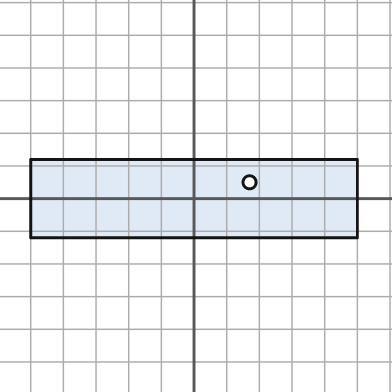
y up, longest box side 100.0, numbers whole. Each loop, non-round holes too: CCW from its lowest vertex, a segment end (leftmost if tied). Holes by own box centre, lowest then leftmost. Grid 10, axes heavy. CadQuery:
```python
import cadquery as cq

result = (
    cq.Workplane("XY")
    .moveTo(-50.0, -12.0)
    .lineTo(50.0, -12.0)
    .lineTo(50.0, 12.0)
    .lineTo(-50.0, 12.0)
    .close()
    .moveTo(17.0, 5.0)
    .circle(2.0)
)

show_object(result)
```